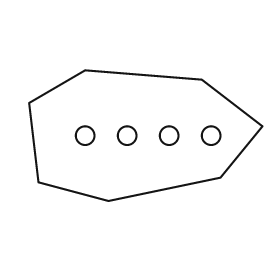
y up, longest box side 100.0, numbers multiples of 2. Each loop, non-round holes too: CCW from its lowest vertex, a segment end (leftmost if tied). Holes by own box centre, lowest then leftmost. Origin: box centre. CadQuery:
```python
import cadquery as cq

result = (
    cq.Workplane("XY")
    .moveTo(-16.0, -28.0)
    .lineTo(32.0, -18.0)
    .lineTo(50.0, 4.0)
    .lineTo(24.0, 24.0)
    .lineTo(-26.0, 28.0)
    .lineTo(-50.0, 14.0)
    .lineTo(-46.0, -20.0)
    .close()
    .moveTo(-26.0, 0.0)
    .circle(4.0)
    .moveTo(-8.0, 0.0)
    .circle(4.0)
    .moveTo(10.0, 0.0)
    .circle(4.0)
    .moveTo(28.0, 0.0)
    .circle(4.0)
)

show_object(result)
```